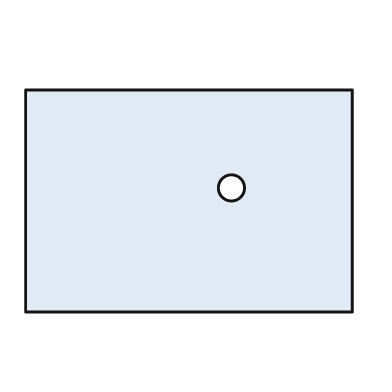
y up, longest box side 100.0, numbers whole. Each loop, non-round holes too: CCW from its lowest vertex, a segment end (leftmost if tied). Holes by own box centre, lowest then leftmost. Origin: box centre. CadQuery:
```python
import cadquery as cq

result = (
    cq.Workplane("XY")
    .moveTo(-50.0, -34.0)
    .lineTo(50.0, -34.0)
    .lineTo(50.0, 34.0)
    .lineTo(-50.0, 34.0)
    .close()
    .moveTo(13.0, 4.0)
    .circle(4.0)
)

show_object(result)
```